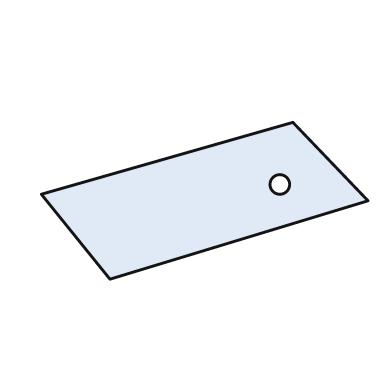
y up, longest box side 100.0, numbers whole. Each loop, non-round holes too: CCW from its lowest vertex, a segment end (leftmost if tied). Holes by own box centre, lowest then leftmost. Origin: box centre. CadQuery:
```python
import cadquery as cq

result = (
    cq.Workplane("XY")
    .moveTo(-29.0, -24.0)
    .lineTo(50.0, 0.0)
    .lineTo(27.0, 24.0)
    .lineTo(-50.0, 2.0)
    .close()
    .moveTo(23.0, 5.0)
    .circle(3.0)
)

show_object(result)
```